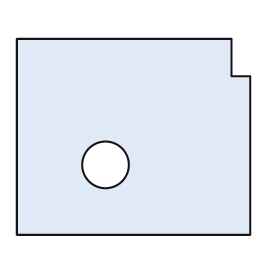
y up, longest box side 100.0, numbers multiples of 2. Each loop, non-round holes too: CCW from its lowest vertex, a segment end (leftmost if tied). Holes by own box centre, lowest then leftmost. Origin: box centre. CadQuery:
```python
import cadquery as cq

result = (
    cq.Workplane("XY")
    .moveTo(-50.0, -42.0)
    .lineTo(50.0, -42.0)
    .lineTo(50.0, 26.0)
    .lineTo(42.0, 26.0)
    .lineTo(42.0, 42.0)
    .lineTo(-50.0, 42.0)
    .close()
    .moveTo(-12.0, -12.0)
    .circle(10.0)
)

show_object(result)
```